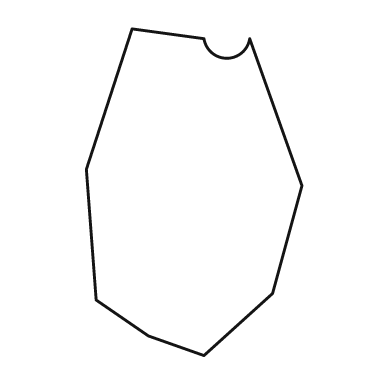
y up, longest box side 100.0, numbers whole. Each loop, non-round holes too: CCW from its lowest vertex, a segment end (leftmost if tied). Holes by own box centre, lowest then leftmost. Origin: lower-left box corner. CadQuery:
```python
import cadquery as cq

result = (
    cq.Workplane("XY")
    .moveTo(36.0, 0.0)
    .lineTo(57.0, 19.0)
    .lineTo(66.0, 52.0)
    .lineTo(50.0, 97.0)
    .threePointArc((43.0, 91.0), (36.0, 97.0))
    .lineTo(14.0, 100.0)
    .lineTo(0.0, 57.0)
    .lineTo(3.0, 17.0)
    .lineTo(19.0, 6.0)
    .close()
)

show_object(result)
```